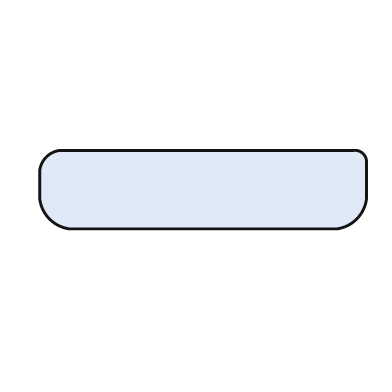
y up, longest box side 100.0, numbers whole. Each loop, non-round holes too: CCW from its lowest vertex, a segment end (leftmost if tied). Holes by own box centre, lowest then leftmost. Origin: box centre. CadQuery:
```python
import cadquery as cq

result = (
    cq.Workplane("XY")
    .moveTo(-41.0, -12.0)
    .lineTo(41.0, -12.0)
    .threePointArc((47.0, -9.0), (50.0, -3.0))
    .lineTo(50.0, 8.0)
    .threePointArc((49.0, 11.0), (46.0, 12.0))
    .lineTo(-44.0, 12.0)
    .threePointArc((-48.0, 10.0), (-50.0, 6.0))
    .lineTo(-50.0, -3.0)
    .threePointArc((-47.0, -9.0), (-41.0, -12.0))
    .close()
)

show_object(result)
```